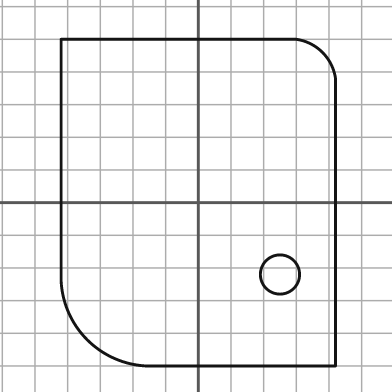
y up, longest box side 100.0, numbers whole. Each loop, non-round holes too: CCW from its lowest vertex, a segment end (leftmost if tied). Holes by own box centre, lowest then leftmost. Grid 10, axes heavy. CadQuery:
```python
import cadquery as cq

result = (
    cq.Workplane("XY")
    .moveTo(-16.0, -50.0)
    .lineTo(42.0, -50.0)
    .lineTo(42.0, 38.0)
    .threePointArc((38.0, 46.0), (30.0, 50.0))
    .lineTo(-42.0, 50.0)
    .lineTo(-42.0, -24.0)
    .threePointArc((-34.0, -42.0), (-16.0, -50.0))
    .close()
    .moveTo(25.0, -22.0)
    .circle(6.0)
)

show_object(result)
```